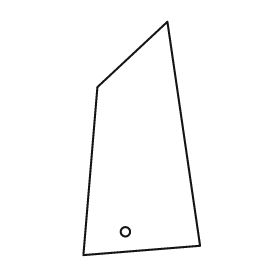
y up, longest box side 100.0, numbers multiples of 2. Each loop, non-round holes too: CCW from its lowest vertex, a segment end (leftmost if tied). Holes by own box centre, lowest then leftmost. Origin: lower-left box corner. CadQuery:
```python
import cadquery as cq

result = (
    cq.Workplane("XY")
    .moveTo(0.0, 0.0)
    .lineTo(50.0, 4.0)
    .lineTo(36.0, 100.0)
    .lineTo(6.0, 72.0)
    .close()
    .moveTo(18.0, 10.0)
    .circle(2.0)
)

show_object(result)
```